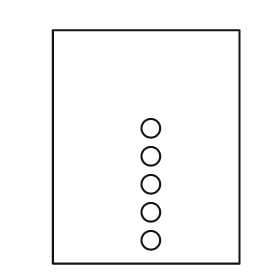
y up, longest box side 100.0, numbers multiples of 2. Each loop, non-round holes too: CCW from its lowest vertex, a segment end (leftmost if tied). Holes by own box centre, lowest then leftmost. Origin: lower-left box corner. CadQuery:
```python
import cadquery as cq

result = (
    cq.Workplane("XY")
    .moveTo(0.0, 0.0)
    .lineTo(80.0, 0.0)
    .lineTo(80.0, 100.0)
    .lineTo(0.0, 100.0)
    .close()
    .moveTo(42.0, 10.0)
    .circle(4.0)
    .moveTo(42.0, 22.0)
    .circle(4.0)
    .moveTo(42.0, 34.0)
    .circle(4.0)
    .moveTo(42.0, 46.0)
    .circle(4.0)
    .moveTo(42.0, 58.0)
    .circle(4.0)
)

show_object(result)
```